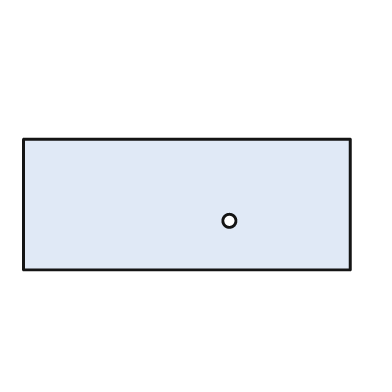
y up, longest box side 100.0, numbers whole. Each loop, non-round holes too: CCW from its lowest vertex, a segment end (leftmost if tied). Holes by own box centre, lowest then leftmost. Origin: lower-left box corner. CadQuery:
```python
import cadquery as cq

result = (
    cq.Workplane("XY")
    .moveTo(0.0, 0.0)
    .lineTo(100.0, 0.0)
    .lineTo(100.0, 40.0)
    .lineTo(0.0, 40.0)
    .close()
    .moveTo(63.0, 15.0)
    .circle(2.0)
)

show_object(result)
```